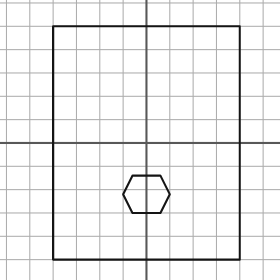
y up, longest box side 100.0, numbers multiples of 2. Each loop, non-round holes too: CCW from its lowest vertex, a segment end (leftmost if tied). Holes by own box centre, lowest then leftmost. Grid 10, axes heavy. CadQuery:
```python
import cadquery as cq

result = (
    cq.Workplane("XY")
    .moveTo(-40.0, -50.0)
    .lineTo(40.0, -50.0)
    .lineTo(40.0, 50.0)
    .lineTo(-40.0, 50.0)
    .close()
    .moveTo(-6.0, -30.0)
    .lineTo(6.0, -30.0)
    .lineTo(10.0, -22.0)
    .lineTo(6.0, -14.0)
    .lineTo(-6.0, -14.0)
    .lineTo(-10.0, -22.0)
    .close()
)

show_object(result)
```